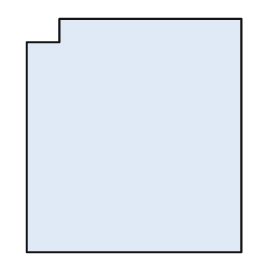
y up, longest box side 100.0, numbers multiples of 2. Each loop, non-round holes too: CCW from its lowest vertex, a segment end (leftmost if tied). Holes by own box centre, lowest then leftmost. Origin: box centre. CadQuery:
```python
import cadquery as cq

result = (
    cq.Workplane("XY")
    .moveTo(-46.0, -50.0)
    .lineTo(46.0, -50.0)
    .lineTo(46.0, 50.0)
    .lineTo(-32.0, 50.0)
    .lineTo(-32.0, 40.0)
    .lineTo(-46.0, 40.0)
    .close()
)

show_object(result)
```